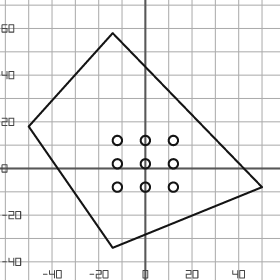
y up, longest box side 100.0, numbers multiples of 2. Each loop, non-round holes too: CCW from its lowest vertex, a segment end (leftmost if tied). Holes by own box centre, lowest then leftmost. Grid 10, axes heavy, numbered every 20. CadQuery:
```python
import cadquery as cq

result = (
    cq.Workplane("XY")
    .moveTo(-14.0, -34.0)
    .lineTo(50.0, -8.0)
    .lineTo(-14.0, 58.0)
    .lineTo(-50.0, 18.0)
    .close()
    .moveTo(-12.0, -8.0)
    .circle(2.0)
    .moveTo(0.0, -8.0)
    .circle(2.0)
    .moveTo(12.0, -8.0)
    .circle(2.0)
    .moveTo(-12.0, 2.0)
    .circle(2.0)
    .moveTo(0.0, 2.0)
    .circle(2.0)
    .moveTo(12.0, 2.0)
    .circle(2.0)
    .moveTo(-12.0, 12.0)
    .circle(2.0)
    .moveTo(0.0, 12.0)
    .circle(2.0)
    .moveTo(12.0, 12.0)
    .circle(2.0)
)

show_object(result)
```